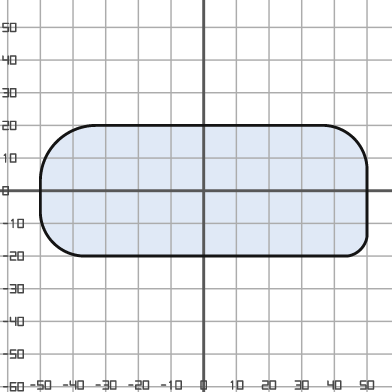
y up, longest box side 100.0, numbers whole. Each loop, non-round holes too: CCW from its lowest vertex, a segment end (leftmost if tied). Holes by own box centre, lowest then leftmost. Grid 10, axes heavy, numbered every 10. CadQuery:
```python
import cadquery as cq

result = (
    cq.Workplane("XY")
    .moveTo(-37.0, -20.0)
    .lineTo(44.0, -20.0)
    .threePointArc((48.0, -18.0), (50.0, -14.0))
    .lineTo(50.0, 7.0)
    .threePointArc((46.0, 16.0), (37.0, 20.0))
    .lineTo(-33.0, 20.0)
    .threePointArc((-45.0, 15.0), (-50.0, 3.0))
    .lineTo(-50.0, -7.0)
    .threePointArc((-46.0, -16.0), (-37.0, -20.0))
    .close()
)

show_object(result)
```